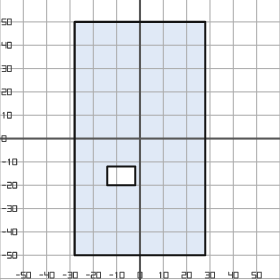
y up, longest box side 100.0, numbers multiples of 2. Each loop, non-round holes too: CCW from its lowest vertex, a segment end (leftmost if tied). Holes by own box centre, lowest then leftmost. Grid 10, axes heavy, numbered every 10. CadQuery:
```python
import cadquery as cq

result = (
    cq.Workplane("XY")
    .moveTo(-28.0, -50.0)
    .lineTo(28.0, -50.0)
    .lineTo(28.0, 50.0)
    .lineTo(-28.0, 50.0)
    .close()
    .moveTo(-14.0, -20.0)
    .lineTo(-2.0, -20.0)
    .lineTo(-2.0, -12.0)
    .lineTo(-14.0, -12.0)
    .close()
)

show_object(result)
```